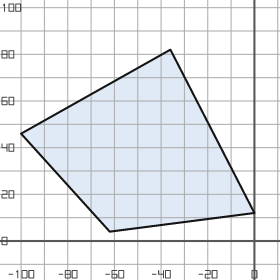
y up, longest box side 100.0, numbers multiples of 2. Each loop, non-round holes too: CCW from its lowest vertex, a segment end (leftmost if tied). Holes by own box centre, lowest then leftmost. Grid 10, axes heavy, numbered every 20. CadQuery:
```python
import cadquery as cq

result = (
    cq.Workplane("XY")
    .moveTo(-62.0, 4.0)
    .lineTo(0.0, 12.0)
    .lineTo(-36.0, 82.0)
    .lineTo(-100.0, 46.0)
    .close()
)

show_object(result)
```